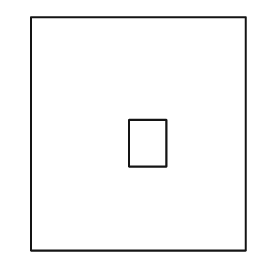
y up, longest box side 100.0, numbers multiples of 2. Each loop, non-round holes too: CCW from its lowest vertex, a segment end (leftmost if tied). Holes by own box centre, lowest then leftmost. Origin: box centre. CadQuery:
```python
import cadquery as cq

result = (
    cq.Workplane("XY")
    .moveTo(-46.0, -50.0)
    .lineTo(46.0, -50.0)
    .lineTo(46.0, 50.0)
    .lineTo(-46.0, 50.0)
    .close()
    .moveTo(-4.0, -14.0)
    .lineTo(12.0, -14.0)
    .lineTo(12.0, 6.0)
    .lineTo(-4.0, 6.0)
    .close()
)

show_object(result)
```